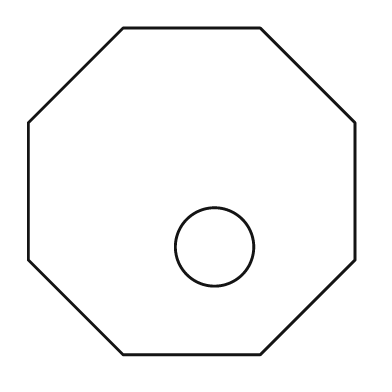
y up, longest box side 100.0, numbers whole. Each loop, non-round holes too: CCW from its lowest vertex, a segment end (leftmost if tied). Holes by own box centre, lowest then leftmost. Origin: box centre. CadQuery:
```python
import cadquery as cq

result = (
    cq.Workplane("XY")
    .moveTo(-21.0, -50.0)
    .lineTo(21.0, -50.0)
    .lineTo(50.0, -21.0)
    .lineTo(50.0, 21.0)
    .lineTo(21.0, 50.0)
    .lineTo(-21.0, 50.0)
    .lineTo(-50.0, 21.0)
    .lineTo(-50.0, -21.0)
    .close()
    .moveTo(7.0, -17.0)
    .circle(12.0)
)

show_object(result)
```